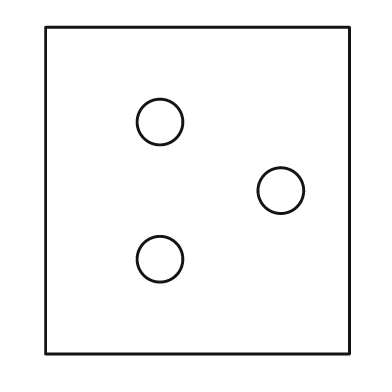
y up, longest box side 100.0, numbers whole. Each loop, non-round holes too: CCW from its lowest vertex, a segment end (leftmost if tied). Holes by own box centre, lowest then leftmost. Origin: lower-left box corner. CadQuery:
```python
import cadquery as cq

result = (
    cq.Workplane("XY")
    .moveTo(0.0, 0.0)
    .lineTo(93.0, 0.0)
    .lineTo(93.0, 100.0)
    .lineTo(0.0, 100.0)
    .close()
    .moveTo(35.0, 29.0)
    .circle(7.0)
    .moveTo(72.0, 50.0)
    .circle(7.0)
    .moveTo(35.0, 71.0)
    .circle(7.0)
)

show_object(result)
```